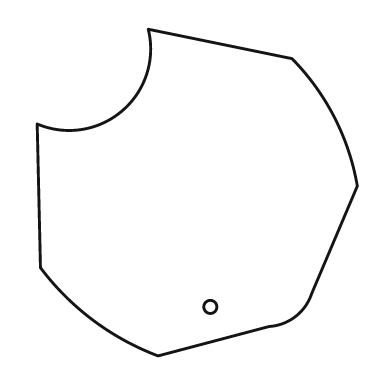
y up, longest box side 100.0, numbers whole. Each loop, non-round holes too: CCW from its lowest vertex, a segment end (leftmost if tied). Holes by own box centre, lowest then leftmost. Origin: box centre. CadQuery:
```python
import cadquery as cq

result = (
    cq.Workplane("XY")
    .moveTo(-12.0, -50.0)
    .lineTo(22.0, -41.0)
    .threePointArc((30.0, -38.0), (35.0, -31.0))
    .lineTo(49.0, 2.0)
    .threePointArc((42.0, 23.0), (29.0, 41.0))
    .lineTo(-15.0, 50.0)
    .threePointArc((-23.0, 25.0), (-49.0, 21.0))
    .lineTo(-48.0, -23.0)
    .threePointArc((-32.0, -39.0), (-12.0, -50.0))
    .close()
    .moveTo(4.0, -35.0)
    .circle(2.0)
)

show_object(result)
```